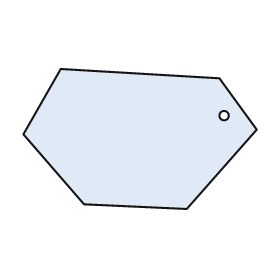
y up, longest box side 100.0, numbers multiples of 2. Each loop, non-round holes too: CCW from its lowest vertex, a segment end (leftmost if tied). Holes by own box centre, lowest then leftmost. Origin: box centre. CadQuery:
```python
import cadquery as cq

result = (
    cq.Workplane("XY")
    .moveTo(20.0, -30.0)
    .lineTo(50.0, 4.0)
    .lineTo(34.0, 26.0)
    .lineTo(-34.0, 30.0)
    .lineTo(-50.0, 2.0)
    .lineTo(-24.0, -28.0)
    .close()
    .moveTo(36.0, 10.0)
    .circle(2.0)
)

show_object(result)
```